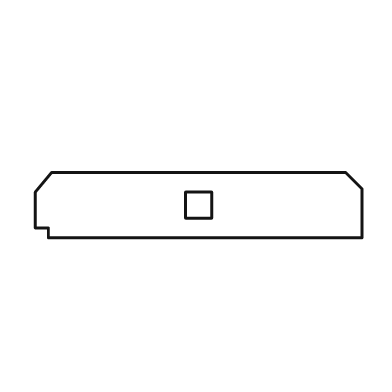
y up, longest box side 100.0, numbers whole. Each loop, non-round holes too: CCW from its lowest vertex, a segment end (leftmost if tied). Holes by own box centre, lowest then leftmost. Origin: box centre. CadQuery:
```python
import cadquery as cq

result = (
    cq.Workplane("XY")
    .moveTo(-46.0, -10.0)
    .lineTo(50.0, -10.0)
    .lineTo(50.0, 5.0)
    .lineTo(45.0, 10.0)
    .lineTo(-45.0, 10.0)
    .lineTo(-50.0, 4.0)
    .lineTo(-50.0, -7.0)
    .lineTo(-46.0, -7.0)
    .close()
    .moveTo(-4.0, -4.0)
    .lineTo(4.0, -4.0)
    .lineTo(4.0, 4.0)
    .lineTo(-4.0, 4.0)
    .close()
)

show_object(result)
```